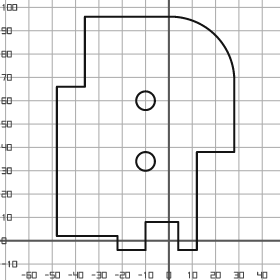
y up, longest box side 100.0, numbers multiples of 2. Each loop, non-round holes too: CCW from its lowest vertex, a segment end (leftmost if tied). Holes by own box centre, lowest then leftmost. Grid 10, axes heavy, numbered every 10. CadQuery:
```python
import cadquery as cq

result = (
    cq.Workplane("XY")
    .moveTo(-22.0, -4.0)
    .lineTo(-10.0, -4.0)
    .lineTo(-10.0, 8.0)
    .lineTo(4.0, 8.0)
    .lineTo(4.0, -4.0)
    .lineTo(12.0, -4.0)
    .lineTo(12.0, 38.0)
    .lineTo(28.0, 38.0)
    .lineTo(28.0, 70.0)
    .threePointArc((20.0, 88.0), (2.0, 96.0))
    .lineTo(-36.0, 96.0)
    .lineTo(-36.0, 66.0)
    .lineTo(-48.0, 66.0)
    .lineTo(-48.0, 2.0)
    .lineTo(-22.0, 2.0)
    .close()
    .moveTo(-10.0, 34.0)
    .circle(4.0)
    .moveTo(-10.0, 60.0)
    .circle(4.0)
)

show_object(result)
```